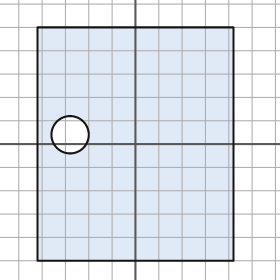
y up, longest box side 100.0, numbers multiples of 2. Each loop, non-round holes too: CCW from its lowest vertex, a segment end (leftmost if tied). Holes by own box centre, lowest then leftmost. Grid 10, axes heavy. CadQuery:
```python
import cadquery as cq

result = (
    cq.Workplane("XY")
    .moveTo(-42.0, -50.0)
    .lineTo(42.0, -50.0)
    .lineTo(42.0, 50.0)
    .lineTo(-42.0, 50.0)
    .close()
    .moveTo(-28.0, 4.0)
    .circle(8.0)
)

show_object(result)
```